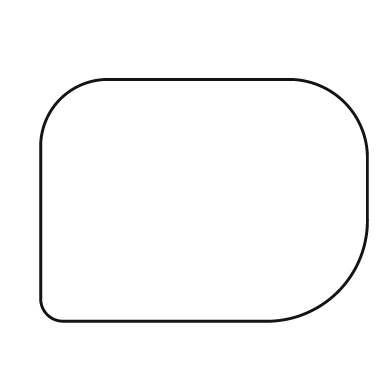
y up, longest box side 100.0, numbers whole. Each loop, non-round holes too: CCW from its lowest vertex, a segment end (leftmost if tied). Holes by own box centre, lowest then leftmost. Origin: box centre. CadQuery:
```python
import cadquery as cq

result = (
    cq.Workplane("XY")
    .moveTo(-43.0, -37.0)
    .lineTo(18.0, -37.0)
    .threePointArc((41.0, -28.0), (50.0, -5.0))
    .lineTo(50.0, 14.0)
    .threePointArc((43.0, 30.0), (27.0, 37.0))
    .lineTo(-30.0, 37.0)
    .threePointArc((-44.0, 31.0), (-50.0, 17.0))
    .lineTo(-50.0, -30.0)
    .threePointArc((-48.0, -35.0), (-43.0, -37.0))
    .close()
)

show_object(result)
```